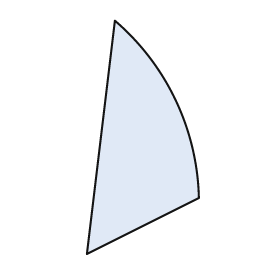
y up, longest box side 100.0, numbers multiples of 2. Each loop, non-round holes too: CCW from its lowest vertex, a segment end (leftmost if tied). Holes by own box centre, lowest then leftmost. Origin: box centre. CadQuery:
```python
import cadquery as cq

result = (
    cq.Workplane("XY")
    .moveTo(-24.0, -50.0)
    .lineTo(24.0, -26.0)
    .threePointArc((14.0, 16.0), (-12.0, 50.0))
    .close()
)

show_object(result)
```